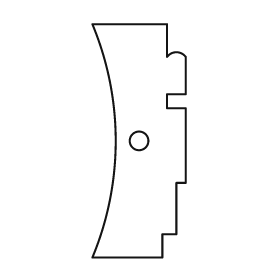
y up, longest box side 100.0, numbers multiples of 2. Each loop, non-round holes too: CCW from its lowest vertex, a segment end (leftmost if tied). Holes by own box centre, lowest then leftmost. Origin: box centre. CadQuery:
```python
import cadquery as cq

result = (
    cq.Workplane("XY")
    .moveTo(-20.0, -50.0)
    .lineTo(10.0, -50.0)
    .lineTo(10.0, -40.0)
    .lineTo(16.0, -40.0)
    .lineTo(16.0, -18.0)
    .lineTo(20.0, -18.0)
    .lineTo(20.0, 14.0)
    .lineTo(12.0, 14.0)
    .lineTo(12.0, 20.0)
    .lineTo(20.0, 20.0)
    .lineTo(20.0, 36.0)
    .threePointArc((16.0, 38.0), (12.0, 36.0))
    .lineTo(12.0, 50.0)
    .lineTo(-20.0, 50.0)
    .threePointArc((-10.0, 0.0), (-20.0, -50.0))
    .close()
    .moveTo(0.0, 0.0)
    .circle(4.0)
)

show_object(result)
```